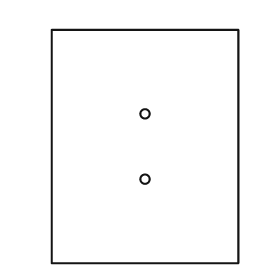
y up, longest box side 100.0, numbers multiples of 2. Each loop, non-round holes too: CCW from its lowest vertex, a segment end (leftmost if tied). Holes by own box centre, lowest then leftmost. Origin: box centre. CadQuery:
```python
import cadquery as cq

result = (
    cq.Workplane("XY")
    .moveTo(-40.0, -50.0)
    .lineTo(40.0, -50.0)
    .lineTo(40.0, 50.0)
    .lineTo(-40.0, 50.0)
    .close()
    .moveTo(0.0, -14.0)
    .circle(2.0)
    .moveTo(0.0, 14.0)
    .circle(2.0)
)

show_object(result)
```